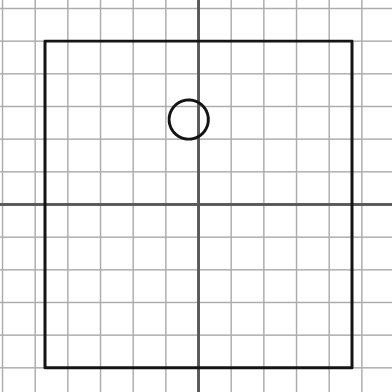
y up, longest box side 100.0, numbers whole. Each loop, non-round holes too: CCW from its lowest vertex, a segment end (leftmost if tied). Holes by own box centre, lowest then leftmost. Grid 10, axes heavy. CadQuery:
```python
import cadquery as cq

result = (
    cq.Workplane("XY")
    .moveTo(-47.0, -50.0)
    .lineTo(47.0, -50.0)
    .lineTo(47.0, 50.0)
    .lineTo(-47.0, 50.0)
    .close()
    .moveTo(-3.0, 26.0)
    .circle(6.0)
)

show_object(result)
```